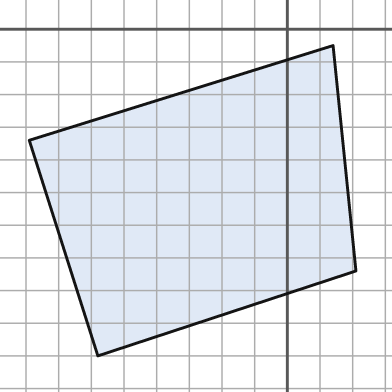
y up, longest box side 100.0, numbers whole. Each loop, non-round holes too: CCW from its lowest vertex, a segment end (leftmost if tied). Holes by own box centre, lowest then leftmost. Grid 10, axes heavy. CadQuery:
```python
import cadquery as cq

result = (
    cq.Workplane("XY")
    .moveTo(-58.0, -100.0)
    .lineTo(21.0, -74.0)
    .lineTo(14.0, -5.0)
    .lineTo(-79.0, -34.0)
    .close()
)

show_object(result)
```